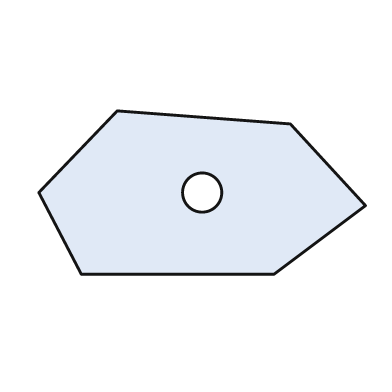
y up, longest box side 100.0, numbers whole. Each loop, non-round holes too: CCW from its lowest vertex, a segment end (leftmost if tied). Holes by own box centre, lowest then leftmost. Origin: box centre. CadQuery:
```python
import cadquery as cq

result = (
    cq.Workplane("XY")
    .moveTo(-37.0, -25.0)
    .lineTo(22.0, -25.0)
    .lineTo(50.0, -4.0)
    .lineTo(27.0, 21.0)
    .lineTo(-26.0, 25.0)
    .lineTo(-50.0, 0.0)
    .close()
    .moveTo(0.0, 0.0)
    .circle(6.0)
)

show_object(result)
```